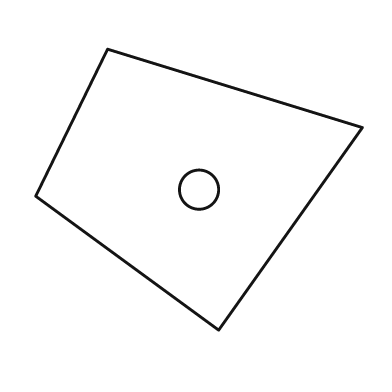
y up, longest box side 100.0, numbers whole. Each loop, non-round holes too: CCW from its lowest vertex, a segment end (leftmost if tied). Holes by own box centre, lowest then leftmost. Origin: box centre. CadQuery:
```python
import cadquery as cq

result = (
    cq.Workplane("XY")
    .moveTo(6.0, -43.0)
    .lineTo(50.0, 19.0)
    .lineTo(-28.0, 43.0)
    .lineTo(-50.0, -2.0)
    .close()
    .moveTo(0.0, 0.0)
    .circle(6.0)
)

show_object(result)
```